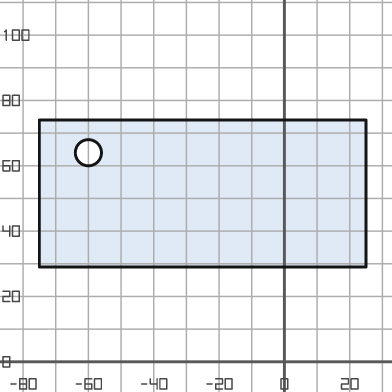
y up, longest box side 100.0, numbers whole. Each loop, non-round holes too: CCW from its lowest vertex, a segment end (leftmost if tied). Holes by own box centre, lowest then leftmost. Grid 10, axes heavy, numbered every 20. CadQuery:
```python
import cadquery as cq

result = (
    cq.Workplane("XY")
    .moveTo(-75.0, 29.0)
    .lineTo(25.0, 29.0)
    .lineTo(25.0, 74.0)
    .lineTo(-75.0, 74.0)
    .close()
    .moveTo(-60.0, 64.0)
    .circle(4.0)
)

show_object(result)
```